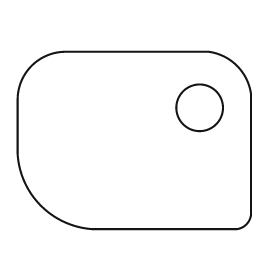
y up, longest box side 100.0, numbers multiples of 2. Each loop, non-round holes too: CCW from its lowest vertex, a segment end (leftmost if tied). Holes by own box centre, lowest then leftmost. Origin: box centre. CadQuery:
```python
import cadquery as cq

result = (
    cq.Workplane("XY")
    .moveTo(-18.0, -38.0)
    .lineTo(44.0, -38.0)
    .threePointArc((48.0, -36.0), (50.0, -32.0))
    .lineTo(50.0, 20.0)
    .threePointArc((44.0, 32.0), (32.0, 38.0))
    .lineTo(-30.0, 38.0)
    .threePointArc((-44.0, 32.0), (-50.0, 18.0))
    .lineTo(-50.0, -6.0)
    .threePointArc((-40.0, -28.0), (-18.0, -38.0))
    .close()
    .moveTo(28.0, 14.0)
    .circle(10.0)
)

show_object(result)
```